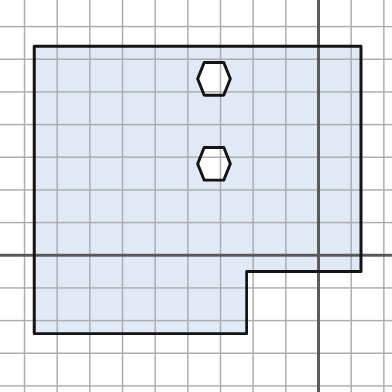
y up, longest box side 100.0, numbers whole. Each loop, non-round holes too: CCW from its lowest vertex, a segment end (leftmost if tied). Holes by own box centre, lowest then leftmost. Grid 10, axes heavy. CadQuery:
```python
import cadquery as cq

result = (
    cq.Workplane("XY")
    .moveTo(-87.0, -24.0)
    .lineTo(-22.0, -24.0)
    .lineTo(-22.0, -5.0)
    .lineTo(13.0, -5.0)
    .lineTo(13.0, 64.0)
    .lineTo(-87.0, 64.0)
    .close()
    .moveTo(-35.0, 23.0)
    .lineTo(-29.0, 23.0)
    .lineTo(-27.0, 28.0)
    .lineTo(-29.0, 33.0)
    .lineTo(-35.0, 33.0)
    .lineTo(-37.0, 28.0)
    .close()
    .moveTo(-35.0, 49.0)
    .lineTo(-29.0, 49.0)
    .lineTo(-27.0, 54.0)
    .lineTo(-29.0, 59.0)
    .lineTo(-35.0, 59.0)
    .lineTo(-37.0, 54.0)
    .close()
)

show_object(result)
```